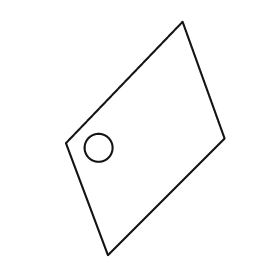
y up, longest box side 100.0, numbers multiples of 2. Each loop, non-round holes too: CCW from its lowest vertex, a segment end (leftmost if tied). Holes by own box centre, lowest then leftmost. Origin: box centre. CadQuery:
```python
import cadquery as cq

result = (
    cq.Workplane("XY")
    .moveTo(-16.0, -50.0)
    .lineTo(34.0, 0.0)
    .lineTo(16.0, 50.0)
    .lineTo(-34.0, -2.0)
    .close()
    .moveTo(-20.0, -4.0)
    .circle(6.0)
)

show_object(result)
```